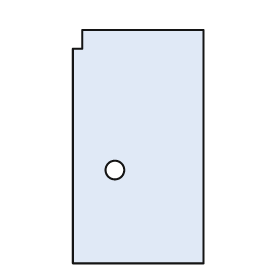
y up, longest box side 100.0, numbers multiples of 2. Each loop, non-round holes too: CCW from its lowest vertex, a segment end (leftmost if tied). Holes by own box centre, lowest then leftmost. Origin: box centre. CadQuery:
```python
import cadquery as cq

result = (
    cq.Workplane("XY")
    .moveTo(-28.0, -50.0)
    .lineTo(28.0, -50.0)
    .lineTo(28.0, 50.0)
    .lineTo(-24.0, 50.0)
    .lineTo(-24.0, 42.0)
    .lineTo(-28.0, 42.0)
    .close()
    .moveTo(-10.0, -10.0)
    .circle(4.0)
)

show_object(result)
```